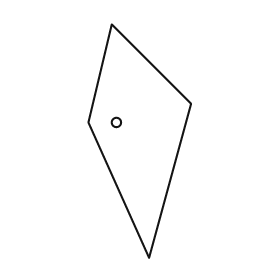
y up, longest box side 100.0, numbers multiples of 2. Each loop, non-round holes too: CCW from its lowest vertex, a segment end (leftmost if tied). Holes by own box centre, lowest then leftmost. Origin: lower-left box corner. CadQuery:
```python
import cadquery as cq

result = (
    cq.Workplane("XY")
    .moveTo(26.0, 0.0)
    .lineTo(44.0, 66.0)
    .lineTo(10.0, 100.0)
    .lineTo(0.0, 58.0)
    .close()
    .moveTo(12.0, 58.0)
    .circle(2.0)
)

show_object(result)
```